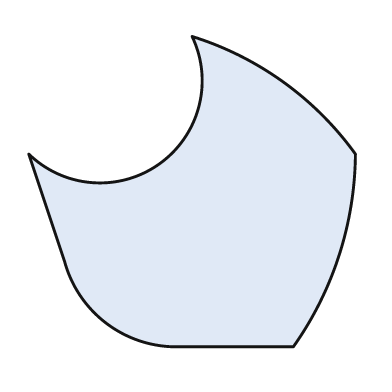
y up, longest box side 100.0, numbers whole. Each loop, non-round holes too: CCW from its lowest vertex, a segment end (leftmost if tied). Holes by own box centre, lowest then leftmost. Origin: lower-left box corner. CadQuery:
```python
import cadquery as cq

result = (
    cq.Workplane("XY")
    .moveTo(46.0, 0.0)
    .lineTo(81.0, 0.0)
    .threePointArc((95.0, 28.0), (100.0, 59.0))
    .threePointArc((78.0, 81.0), (50.0, 95.0))
    .threePointArc((40.0, 56.0), (0.0, 59.0))
    .lineTo(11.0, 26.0)
    .threePointArc((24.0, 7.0), (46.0, 0.0))
    .close()
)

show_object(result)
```